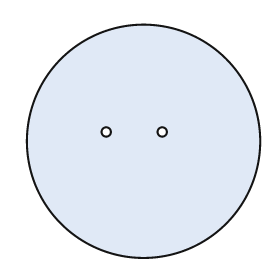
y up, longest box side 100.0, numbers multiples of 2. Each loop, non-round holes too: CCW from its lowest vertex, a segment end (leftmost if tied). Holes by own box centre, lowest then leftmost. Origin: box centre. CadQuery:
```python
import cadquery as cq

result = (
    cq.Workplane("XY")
    .moveTo(0.0, 0.0)
    .circle(50.0)
    .moveTo(-16.0, 4.0)
    .circle(2.0)
    .moveTo(8.0, 4.0)
    .circle(2.0)
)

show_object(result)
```